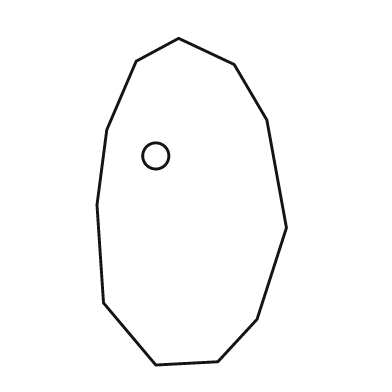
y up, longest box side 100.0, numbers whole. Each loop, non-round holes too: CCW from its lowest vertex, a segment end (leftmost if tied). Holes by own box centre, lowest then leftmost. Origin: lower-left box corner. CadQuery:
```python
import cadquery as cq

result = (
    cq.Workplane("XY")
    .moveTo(18.0, 0.0)
    .lineTo(37.0, 1.0)
    .lineTo(49.0, 14.0)
    .lineTo(58.0, 42.0)
    .lineTo(52.0, 75.0)
    .lineTo(42.0, 92.0)
    .lineTo(25.0, 100.0)
    .lineTo(12.0, 93.0)
    .lineTo(3.0, 72.0)
    .lineTo(0.0, 49.0)
    .lineTo(2.0, 19.0)
    .close()
    .moveTo(18.0, 64.0)
    .circle(4.0)
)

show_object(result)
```